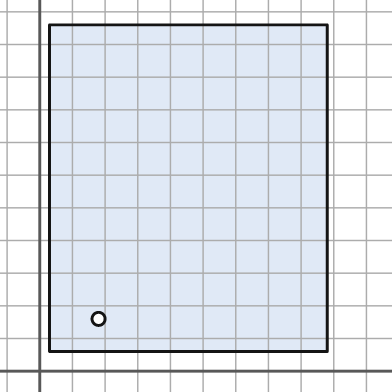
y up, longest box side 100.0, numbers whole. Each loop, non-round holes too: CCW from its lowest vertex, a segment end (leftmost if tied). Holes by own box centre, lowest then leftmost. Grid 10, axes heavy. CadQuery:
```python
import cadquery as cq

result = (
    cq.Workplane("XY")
    .moveTo(3.0, 6.0)
    .lineTo(88.0, 6.0)
    .lineTo(88.0, 106.0)
    .lineTo(3.0, 106.0)
    .close()
    .moveTo(18.0, 16.0)
    .circle(2.0)
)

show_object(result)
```